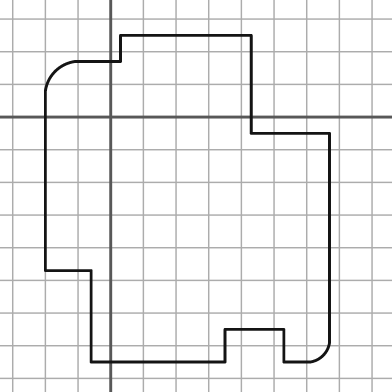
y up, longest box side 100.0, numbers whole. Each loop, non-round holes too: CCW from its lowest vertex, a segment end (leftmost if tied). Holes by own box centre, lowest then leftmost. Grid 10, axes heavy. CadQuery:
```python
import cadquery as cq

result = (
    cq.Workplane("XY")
    .moveTo(-6.0, -75.0)
    .lineTo(35.0, -75.0)
    .lineTo(35.0, -65.0)
    .lineTo(53.0, -65.0)
    .lineTo(53.0, -75.0)
    .lineTo(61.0, -75.0)
    .threePointArc((65.0, -73.0), (67.0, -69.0))
    .lineTo(67.0, -5.0)
    .lineTo(43.0, -5.0)
    .lineTo(43.0, 25.0)
    .lineTo(3.0, 25.0)
    .lineTo(3.0, 17.0)
    .lineTo(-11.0, 17.0)
    .threePointArc((-17.0, 14.0), (-20.0, 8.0))
    .lineTo(-20.0, -47.0)
    .lineTo(-6.0, -47.0)
    .close()
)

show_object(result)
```